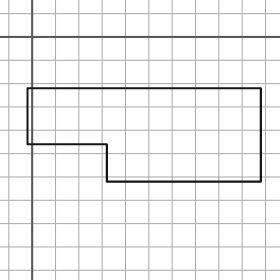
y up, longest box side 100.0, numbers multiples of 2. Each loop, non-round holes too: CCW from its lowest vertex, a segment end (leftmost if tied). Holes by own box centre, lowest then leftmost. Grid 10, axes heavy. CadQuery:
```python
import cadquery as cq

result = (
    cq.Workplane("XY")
    .moveTo(32.0, -62.0)
    .lineTo(98.0, -62.0)
    .lineTo(98.0, -22.0)
    .lineTo(-2.0, -22.0)
    .lineTo(-2.0, -46.0)
    .lineTo(32.0, -46.0)
    .close()
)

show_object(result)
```